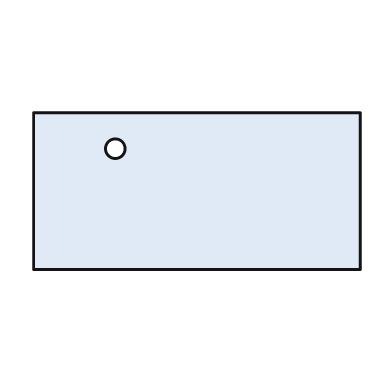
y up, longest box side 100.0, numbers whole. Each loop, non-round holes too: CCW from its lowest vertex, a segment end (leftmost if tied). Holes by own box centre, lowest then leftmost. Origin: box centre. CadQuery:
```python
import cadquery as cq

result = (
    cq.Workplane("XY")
    .moveTo(-50.0, -24.0)
    .lineTo(50.0, -24.0)
    .lineTo(50.0, 24.0)
    .lineTo(-50.0, 24.0)
    .close()
    .moveTo(-25.0, 13.0)
    .circle(3.0)
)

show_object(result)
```